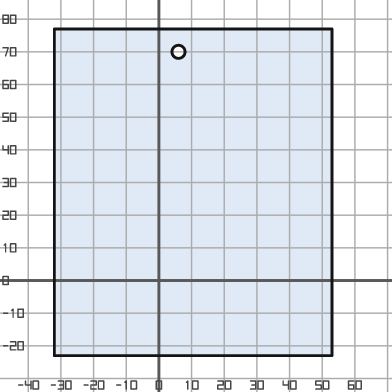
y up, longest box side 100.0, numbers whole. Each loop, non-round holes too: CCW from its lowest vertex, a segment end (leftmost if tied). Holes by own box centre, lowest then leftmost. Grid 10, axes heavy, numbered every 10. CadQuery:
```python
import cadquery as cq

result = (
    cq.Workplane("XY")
    .moveTo(-32.0, -23.0)
    .lineTo(53.0, -23.0)
    .lineTo(53.0, 77.0)
    .lineTo(-32.0, 77.0)
    .close()
    .moveTo(6.0, 70.0)
    .circle(2.0)
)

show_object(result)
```